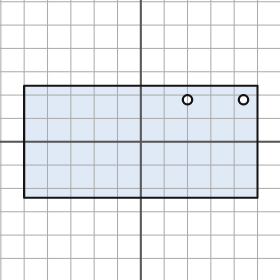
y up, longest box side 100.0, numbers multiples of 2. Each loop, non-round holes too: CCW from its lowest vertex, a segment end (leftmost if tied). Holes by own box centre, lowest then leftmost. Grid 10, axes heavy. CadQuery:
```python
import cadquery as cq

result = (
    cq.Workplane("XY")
    .moveTo(-50.0, -24.0)
    .lineTo(50.0, -24.0)
    .lineTo(50.0, 24.0)
    .lineTo(-50.0, 24.0)
    .close()
    .moveTo(20.0, 18.0)
    .circle(2.0)
    .moveTo(44.0, 18.0)
    .circle(2.0)
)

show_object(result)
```